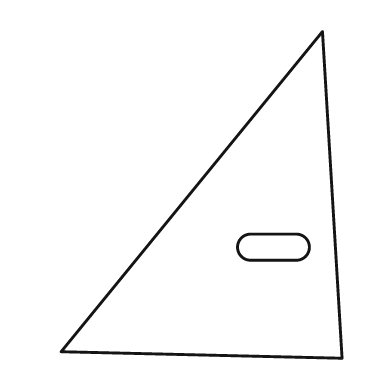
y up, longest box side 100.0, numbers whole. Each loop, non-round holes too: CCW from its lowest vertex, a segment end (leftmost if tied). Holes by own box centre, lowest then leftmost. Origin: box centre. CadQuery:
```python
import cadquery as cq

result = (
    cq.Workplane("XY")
    .moveTo(43.0, -50.0)
    .lineTo(37.0, 50.0)
    .lineTo(-43.0, -48.0)
    .close()
    .moveTo(15.0, -20.0)
    .lineTo(29.0, -20.0)
    .threePointArc((33.0, -16.0), (29.0, -12.0))
    .lineTo(15.0, -12.0)
    .threePointArc((11.0, -16.0), (15.0, -20.0))
    .close()
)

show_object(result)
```